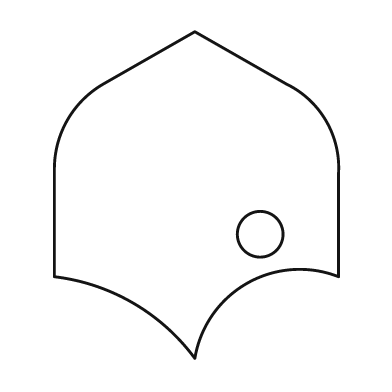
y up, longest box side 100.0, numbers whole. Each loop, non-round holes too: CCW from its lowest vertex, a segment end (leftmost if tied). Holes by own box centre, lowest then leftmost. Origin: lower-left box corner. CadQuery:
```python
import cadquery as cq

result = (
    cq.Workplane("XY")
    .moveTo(43.0, 0.0)
    .threePointArc((59.0, 23.0), (87.0, 25.0))
    .lineTo(87.0, 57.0)
    .threePointArc((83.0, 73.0), (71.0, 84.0))
    .lineTo(43.0, 100.0)
    .lineTo(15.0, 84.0)
    .threePointArc((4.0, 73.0), (0.0, 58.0))
    .lineTo(0.0, 25.0)
    .threePointArc((24.0, 17.0), (43.0, 0.0))
    .close()
    .moveTo(63.0, 38.0)
    .circle(7.0)
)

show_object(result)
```